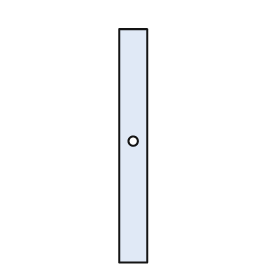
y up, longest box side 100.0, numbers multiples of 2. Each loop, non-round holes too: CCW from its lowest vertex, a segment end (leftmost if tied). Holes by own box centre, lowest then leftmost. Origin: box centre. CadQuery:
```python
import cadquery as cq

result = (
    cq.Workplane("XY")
    .moveTo(-6.0, -50.0)
    .lineTo(6.0, -50.0)
    .lineTo(6.0, 50.0)
    .lineTo(-6.0, 50.0)
    .close()
    .moveTo(0.0, 2.0)
    .circle(2.0)
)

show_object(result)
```